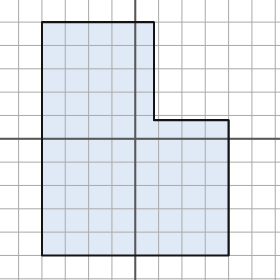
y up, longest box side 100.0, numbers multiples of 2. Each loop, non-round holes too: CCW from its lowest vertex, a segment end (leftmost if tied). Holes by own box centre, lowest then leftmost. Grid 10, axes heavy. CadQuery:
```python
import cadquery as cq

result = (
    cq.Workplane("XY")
    .moveTo(-40.0, -50.0)
    .lineTo(40.0, -50.0)
    .lineTo(40.0, 8.0)
    .lineTo(8.0, 8.0)
    .lineTo(8.0, 50.0)
    .lineTo(-40.0, 50.0)
    .close()
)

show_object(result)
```